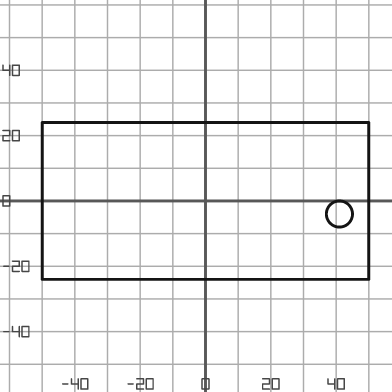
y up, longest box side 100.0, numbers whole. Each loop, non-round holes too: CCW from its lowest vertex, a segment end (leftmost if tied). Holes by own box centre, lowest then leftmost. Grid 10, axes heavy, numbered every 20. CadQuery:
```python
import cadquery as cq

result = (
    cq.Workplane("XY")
    .moveTo(-50.0, -24.0)
    .lineTo(50.0, -24.0)
    .lineTo(50.0, 24.0)
    .lineTo(-50.0, 24.0)
    .close()
    .moveTo(41.0, -4.0)
    .circle(4.0)
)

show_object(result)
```